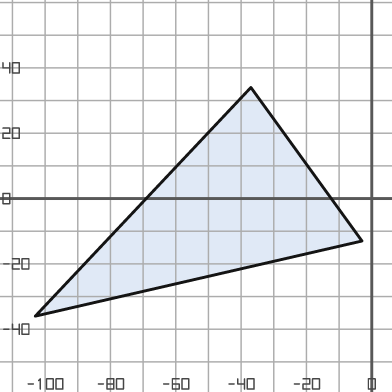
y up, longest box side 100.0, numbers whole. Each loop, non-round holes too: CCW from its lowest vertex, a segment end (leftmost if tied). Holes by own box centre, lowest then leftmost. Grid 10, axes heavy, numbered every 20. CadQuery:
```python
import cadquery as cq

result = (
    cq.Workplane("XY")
    .moveTo(-103.0, -36.0)
    .lineTo(-3.0, -13.0)
    .lineTo(-37.0, 34.0)
    .close()
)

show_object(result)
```